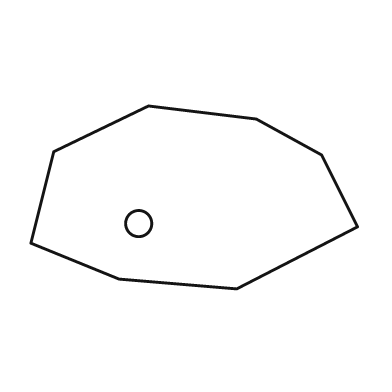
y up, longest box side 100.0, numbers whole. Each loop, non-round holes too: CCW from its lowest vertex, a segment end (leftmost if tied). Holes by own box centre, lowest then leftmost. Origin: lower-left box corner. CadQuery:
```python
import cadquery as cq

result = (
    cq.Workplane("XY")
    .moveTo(63.0, 0.0)
    .lineTo(100.0, 19.0)
    .lineTo(89.0, 41.0)
    .lineTo(69.0, 52.0)
    .lineTo(36.0, 56.0)
    .lineTo(7.0, 42.0)
    .lineTo(0.0, 14.0)
    .lineTo(27.0, 3.0)
    .close()
    .moveTo(33.0, 20.0)
    .circle(4.0)
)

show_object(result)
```